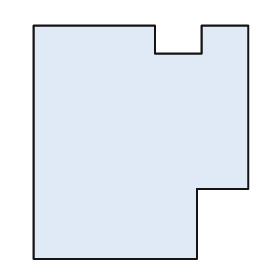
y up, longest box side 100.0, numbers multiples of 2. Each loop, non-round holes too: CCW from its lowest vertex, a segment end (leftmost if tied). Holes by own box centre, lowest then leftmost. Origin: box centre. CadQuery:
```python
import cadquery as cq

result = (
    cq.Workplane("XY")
    .moveTo(-46.0, -50.0)
    .lineTo(24.0, -50.0)
    .lineTo(24.0, -20.0)
    .lineTo(46.0, -20.0)
    .lineTo(46.0, 50.0)
    .lineTo(26.0, 50.0)
    .lineTo(26.0, 38.0)
    .lineTo(6.0, 38.0)
    .lineTo(6.0, 50.0)
    .lineTo(-46.0, 50.0)
    .close()
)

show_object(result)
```